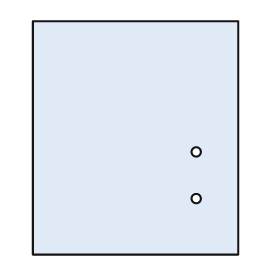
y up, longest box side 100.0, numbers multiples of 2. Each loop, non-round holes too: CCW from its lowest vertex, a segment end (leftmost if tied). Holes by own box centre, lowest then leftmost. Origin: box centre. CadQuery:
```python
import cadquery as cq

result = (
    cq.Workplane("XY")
    .moveTo(-44.0, -50.0)
    .lineTo(44.0, -50.0)
    .lineTo(44.0, 50.0)
    .lineTo(-44.0, 50.0)
    .close()
    .moveTo(26.0, -26.0)
    .circle(2.0)
    .moveTo(26.0, -6.0)
    .circle(2.0)
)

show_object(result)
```